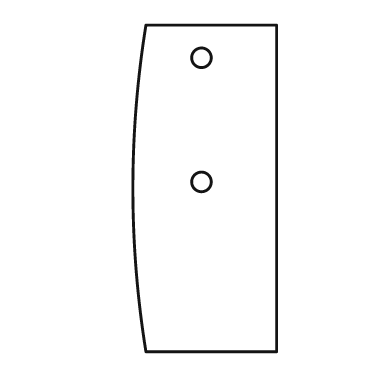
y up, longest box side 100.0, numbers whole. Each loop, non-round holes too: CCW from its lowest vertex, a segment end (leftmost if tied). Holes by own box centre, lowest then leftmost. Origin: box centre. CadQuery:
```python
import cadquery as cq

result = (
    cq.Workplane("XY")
    .moveTo(-18.0, -50.0)
    .lineTo(22.0, -50.0)
    .lineTo(22.0, 50.0)
    .lineTo(-18.0, 50.0)
    .threePointArc((-22.0, 0.0), (-18.0, -50.0))
    .close()
    .moveTo(-1.0, 2.0)
    .circle(3.0)
    .moveTo(-1.0, 40.0)
    .circle(3.0)
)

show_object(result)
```